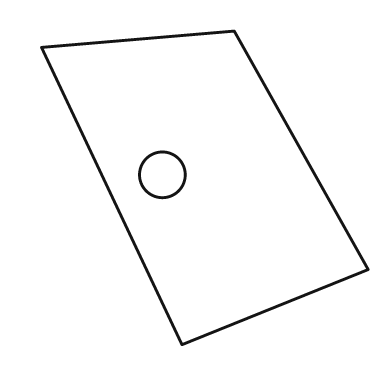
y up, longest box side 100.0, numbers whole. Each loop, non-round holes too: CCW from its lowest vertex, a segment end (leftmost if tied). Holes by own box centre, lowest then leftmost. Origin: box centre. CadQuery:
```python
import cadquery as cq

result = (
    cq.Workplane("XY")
    .moveTo(-7.0, -48.0)
    .lineTo(50.0, -25.0)
    .lineTo(9.0, 48.0)
    .lineTo(-50.0, 43.0)
    .close()
    .moveTo(-13.0, 4.0)
    .circle(7.0)
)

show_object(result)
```